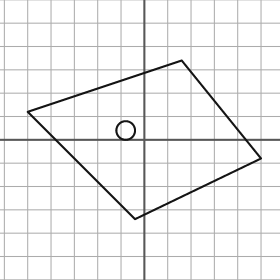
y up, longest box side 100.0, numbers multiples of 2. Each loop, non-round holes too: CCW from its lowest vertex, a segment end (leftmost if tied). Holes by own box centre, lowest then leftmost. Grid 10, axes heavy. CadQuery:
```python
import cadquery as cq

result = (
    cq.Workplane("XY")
    .moveTo(-4.0, -34.0)
    .lineTo(50.0, -8.0)
    .lineTo(16.0, 34.0)
    .lineTo(-50.0, 12.0)
    .close()
    .moveTo(-8.0, 4.0)
    .circle(4.0)
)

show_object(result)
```